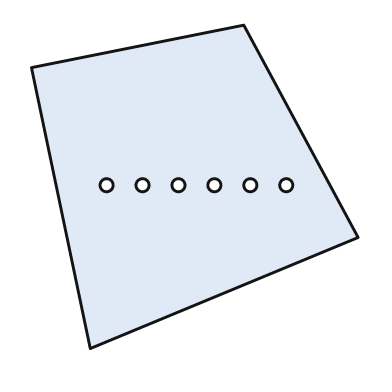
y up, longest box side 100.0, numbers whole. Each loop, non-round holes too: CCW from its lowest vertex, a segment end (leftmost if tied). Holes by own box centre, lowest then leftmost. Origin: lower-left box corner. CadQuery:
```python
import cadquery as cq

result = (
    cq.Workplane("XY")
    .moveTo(18.0, 0.0)
    .lineTo(100.0, 34.0)
    .lineTo(65.0, 99.0)
    .lineTo(0.0, 86.0)
    .close()
    .moveTo(23.0, 50.0)
    .circle(2.0)
    .moveTo(34.0, 50.0)
    .circle(2.0)
    .moveTo(45.0, 50.0)
    .circle(2.0)
    .moveTo(56.0, 50.0)
    .circle(2.0)
    .moveTo(67.0, 50.0)
    .circle(2.0)
    .moveTo(78.0, 50.0)
    .circle(2.0)
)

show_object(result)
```